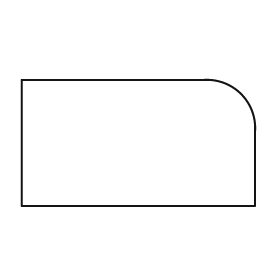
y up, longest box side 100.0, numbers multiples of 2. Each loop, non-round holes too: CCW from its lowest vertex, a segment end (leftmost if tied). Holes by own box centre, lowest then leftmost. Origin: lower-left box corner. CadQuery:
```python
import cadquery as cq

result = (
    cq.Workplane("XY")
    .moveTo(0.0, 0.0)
    .lineTo(100.0, 0.0)
    .lineTo(100.0, 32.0)
    .threePointArc((94.0, 48.0), (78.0, 54.0))
    .lineTo(0.0, 54.0)
    .close()
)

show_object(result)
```